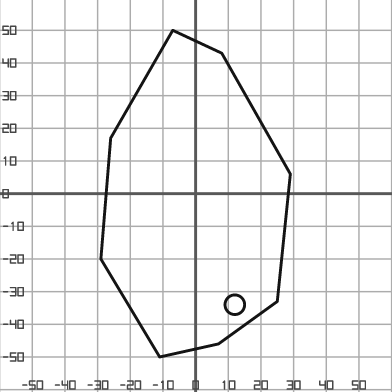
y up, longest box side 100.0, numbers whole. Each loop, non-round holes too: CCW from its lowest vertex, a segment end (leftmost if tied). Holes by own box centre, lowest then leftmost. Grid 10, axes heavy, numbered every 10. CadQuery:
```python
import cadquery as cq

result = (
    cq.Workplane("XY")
    .moveTo(-11.0, -50.0)
    .lineTo(7.0, -46.0)
    .lineTo(25.0, -33.0)
    .lineTo(29.0, 6.0)
    .lineTo(8.0, 43.0)
    .lineTo(-7.0, 50.0)
    .lineTo(-26.0, 17.0)
    .lineTo(-29.0, -20.0)
    .close()
    .moveTo(12.0, -34.0)
    .circle(3.0)
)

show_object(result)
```